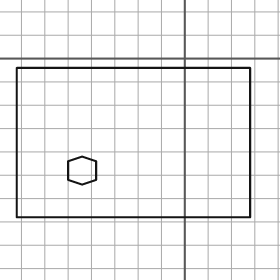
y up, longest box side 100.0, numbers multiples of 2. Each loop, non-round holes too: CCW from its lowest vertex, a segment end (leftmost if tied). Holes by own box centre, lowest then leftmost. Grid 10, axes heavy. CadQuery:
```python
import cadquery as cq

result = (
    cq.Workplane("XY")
    .moveTo(-72.0, -68.0)
    .lineTo(28.0, -68.0)
    .lineTo(28.0, -4.0)
    .lineTo(-72.0, -4.0)
    .close()
    .moveTo(-44.0, -54.0)
    .lineTo(-38.0, -52.0)
    .lineTo(-38.0, -44.0)
    .lineTo(-44.0, -42.0)
    .lineTo(-50.0, -44.0)
    .lineTo(-50.0, -52.0)
    .close()
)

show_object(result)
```